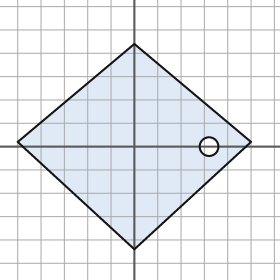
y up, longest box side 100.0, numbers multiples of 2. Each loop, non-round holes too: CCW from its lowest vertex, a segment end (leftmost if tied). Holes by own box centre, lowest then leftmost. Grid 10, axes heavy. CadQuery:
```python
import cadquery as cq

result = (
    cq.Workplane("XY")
    .moveTo(0.0, -44.0)
    .lineTo(50.0, 2.0)
    .lineTo(0.0, 44.0)
    .lineTo(-50.0, 2.0)
    .close()
    .moveTo(32.0, 0.0)
    .circle(4.0)
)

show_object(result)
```